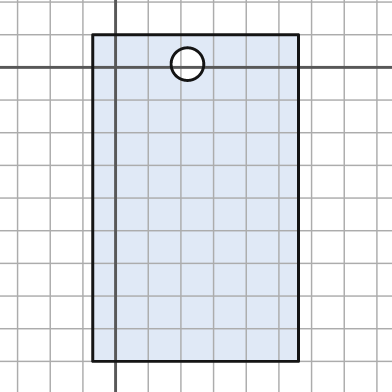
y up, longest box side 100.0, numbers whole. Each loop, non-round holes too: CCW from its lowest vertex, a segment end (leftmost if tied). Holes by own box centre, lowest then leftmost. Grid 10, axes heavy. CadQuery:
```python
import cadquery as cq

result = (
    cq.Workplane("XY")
    .moveTo(-7.0, -90.0)
    .lineTo(56.0, -90.0)
    .lineTo(56.0, 10.0)
    .lineTo(-7.0, 10.0)
    .close()
    .moveTo(22.0, 1.0)
    .circle(5.0)
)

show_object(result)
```